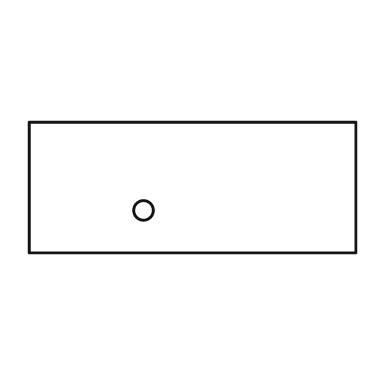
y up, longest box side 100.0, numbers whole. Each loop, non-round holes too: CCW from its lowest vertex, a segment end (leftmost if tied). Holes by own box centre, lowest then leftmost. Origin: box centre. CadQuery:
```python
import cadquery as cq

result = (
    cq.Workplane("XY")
    .moveTo(-50.0, -20.0)
    .lineTo(50.0, -20.0)
    .lineTo(50.0, 20.0)
    .lineTo(-50.0, 20.0)
    .close()
    .moveTo(-15.0, -7.0)
    .circle(3.0)
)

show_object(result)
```